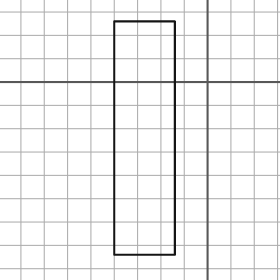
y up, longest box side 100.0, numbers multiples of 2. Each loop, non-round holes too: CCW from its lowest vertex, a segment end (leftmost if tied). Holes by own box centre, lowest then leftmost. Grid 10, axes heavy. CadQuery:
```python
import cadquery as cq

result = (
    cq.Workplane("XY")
    .moveTo(-40.0, -74.0)
    .lineTo(-14.0, -74.0)
    .lineTo(-14.0, 26.0)
    .lineTo(-40.0, 26.0)
    .close()
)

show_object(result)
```